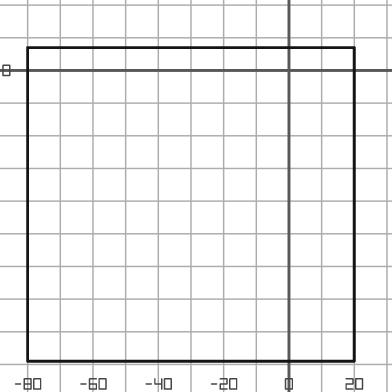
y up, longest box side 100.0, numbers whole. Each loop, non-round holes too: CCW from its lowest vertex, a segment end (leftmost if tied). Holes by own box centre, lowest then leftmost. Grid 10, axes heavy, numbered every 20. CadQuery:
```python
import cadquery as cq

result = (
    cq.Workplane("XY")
    .moveTo(-80.0, -89.0)
    .lineTo(20.0, -89.0)
    .lineTo(20.0, 7.0)
    .lineTo(-80.0, 7.0)
    .close()
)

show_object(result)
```